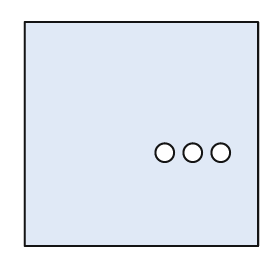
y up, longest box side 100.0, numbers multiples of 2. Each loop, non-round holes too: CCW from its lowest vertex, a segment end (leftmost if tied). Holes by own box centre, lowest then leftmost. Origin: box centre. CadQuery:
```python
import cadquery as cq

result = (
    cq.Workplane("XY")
    .moveTo(-50.0, -48.0)
    .lineTo(50.0, -48.0)
    .lineTo(50.0, 48.0)
    .lineTo(-50.0, 48.0)
    .close()
    .moveTo(10.0, -8.0)
    .circle(4.0)
    .moveTo(22.0, -8.0)
    .circle(4.0)
    .moveTo(34.0, -8.0)
    .circle(4.0)
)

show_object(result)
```